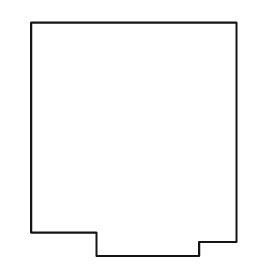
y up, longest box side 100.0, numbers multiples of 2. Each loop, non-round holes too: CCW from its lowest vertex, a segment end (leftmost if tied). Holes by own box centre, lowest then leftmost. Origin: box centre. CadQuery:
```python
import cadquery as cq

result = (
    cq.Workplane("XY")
    .moveTo(-16.0, -50.0)
    .lineTo(28.0, -50.0)
    .lineTo(28.0, -44.0)
    .lineTo(44.0, -44.0)
    .lineTo(44.0, 50.0)
    .lineTo(-44.0, 50.0)
    .lineTo(-44.0, -40.0)
    .lineTo(-16.0, -40.0)
    .close()
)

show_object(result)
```